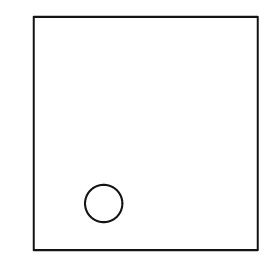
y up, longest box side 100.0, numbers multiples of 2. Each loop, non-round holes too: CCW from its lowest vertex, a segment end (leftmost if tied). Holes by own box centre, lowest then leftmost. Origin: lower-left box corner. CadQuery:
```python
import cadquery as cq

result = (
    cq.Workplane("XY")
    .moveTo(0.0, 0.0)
    .lineTo(96.0, 0.0)
    .lineTo(96.0, 100.0)
    .lineTo(0.0, 100.0)
    .close()
    .moveTo(30.0, 20.0)
    .circle(8.0)
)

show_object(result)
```